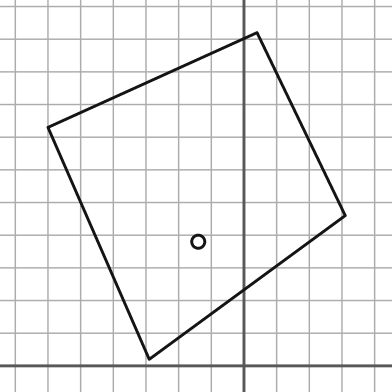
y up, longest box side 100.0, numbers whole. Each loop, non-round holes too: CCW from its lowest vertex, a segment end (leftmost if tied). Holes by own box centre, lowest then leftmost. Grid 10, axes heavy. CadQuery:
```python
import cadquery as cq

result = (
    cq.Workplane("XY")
    .moveTo(-29.0, 2.0)
    .lineTo(31.0, 46.0)
    .lineTo(4.0, 102.0)
    .lineTo(-60.0, 73.0)
    .close()
    .moveTo(-14.0, 38.0)
    .circle(2.0)
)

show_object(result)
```